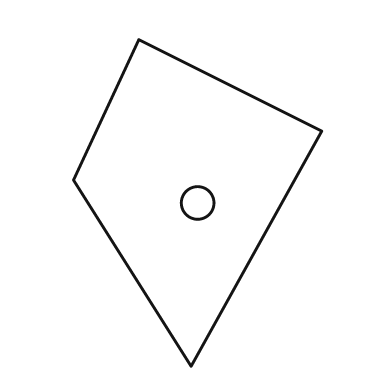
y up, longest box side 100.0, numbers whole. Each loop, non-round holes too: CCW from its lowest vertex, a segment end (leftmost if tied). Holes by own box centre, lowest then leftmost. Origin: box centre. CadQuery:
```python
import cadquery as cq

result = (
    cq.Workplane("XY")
    .moveTo(-2.0, -50.0)
    .lineTo(38.0, 22.0)
    .lineTo(-18.0, 50.0)
    .lineTo(-38.0, 7.0)
    .close()
    .moveTo(0.0, 0.0)
    .circle(5.0)
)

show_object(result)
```